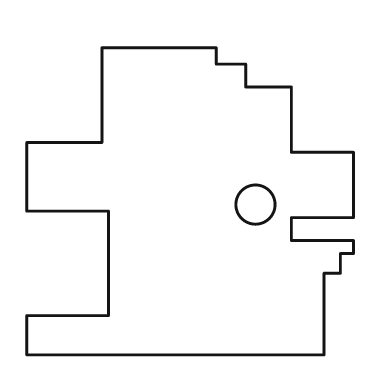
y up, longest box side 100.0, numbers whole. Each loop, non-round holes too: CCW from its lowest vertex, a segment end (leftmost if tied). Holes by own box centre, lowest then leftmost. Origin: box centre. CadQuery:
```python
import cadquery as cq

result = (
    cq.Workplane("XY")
    .moveTo(-50.0, -47.0)
    .lineTo(41.0, -47.0)
    .lineTo(41.0, -22.0)
    .lineTo(46.0, -22.0)
    .lineTo(46.0, -16.0)
    .lineTo(50.0, -16.0)
    .lineTo(50.0, -12.0)
    .lineTo(31.0, -12.0)
    .lineTo(31.0, -5.0)
    .lineTo(50.0, -5.0)
    .lineTo(50.0, 15.0)
    .lineTo(31.0, 15.0)
    .lineTo(31.0, 35.0)
    .lineTo(17.0, 35.0)
    .lineTo(17.0, 42.0)
    .lineTo(8.0, 42.0)
    .lineTo(8.0, 47.0)
    .lineTo(-27.0, 47.0)
    .lineTo(-27.0, 18.0)
    .lineTo(-50.0, 18.0)
    .lineTo(-50.0, -3.0)
    .lineTo(-25.0, -3.0)
    .lineTo(-25.0, -35.0)
    .lineTo(-50.0, -35.0)
    .close()
    .moveTo(20.0, -1.0)
    .circle(6.0)
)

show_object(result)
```